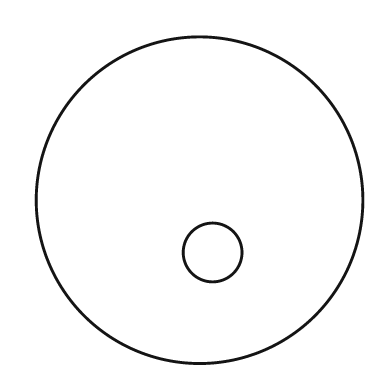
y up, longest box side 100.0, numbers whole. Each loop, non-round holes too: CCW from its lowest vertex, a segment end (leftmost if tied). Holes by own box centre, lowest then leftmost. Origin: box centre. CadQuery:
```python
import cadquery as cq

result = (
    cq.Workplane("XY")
    .moveTo(0.0, 0.0)
    .circle(50.0)
    .moveTo(4.0, -16.0)
    .circle(9.0)
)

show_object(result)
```